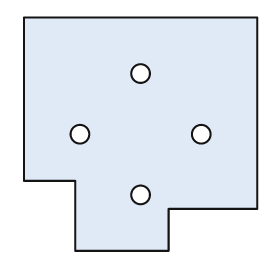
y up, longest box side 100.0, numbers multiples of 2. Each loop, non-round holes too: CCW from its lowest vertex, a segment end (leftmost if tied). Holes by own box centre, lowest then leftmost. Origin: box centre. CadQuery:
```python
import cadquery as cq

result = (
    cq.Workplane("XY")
    .moveTo(-28.0, -50.0)
    .lineTo(12.0, -50.0)
    .lineTo(12.0, -32.0)
    .lineTo(50.0, -32.0)
    .lineTo(50.0, 50.0)
    .lineTo(-50.0, 50.0)
    .lineTo(-50.0, -20.0)
    .lineTo(-28.0, -20.0)
    .close()
    .moveTo(0.0, -26.0)
    .circle(4.0)
    .moveTo(-26.0, 0.0)
    .circle(4.0)
    .moveTo(26.0, 0.0)
    .circle(4.0)
    .moveTo(0.0, 26.0)
    .circle(4.0)
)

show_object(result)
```